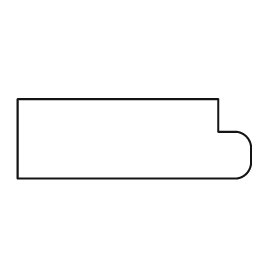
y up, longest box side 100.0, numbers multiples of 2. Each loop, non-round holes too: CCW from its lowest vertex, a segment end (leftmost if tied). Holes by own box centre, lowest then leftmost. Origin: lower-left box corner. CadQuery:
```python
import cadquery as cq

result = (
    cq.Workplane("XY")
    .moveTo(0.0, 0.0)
    .lineTo(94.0, 0.0)
    .threePointArc((98.0, 2.0), (100.0, 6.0))
    .lineTo(100.0, 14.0)
    .threePointArc((98.0, 18.0), (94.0, 20.0))
    .lineTo(86.0, 20.0)
    .lineTo(86.0, 34.0)
    .lineTo(0.0, 34.0)
    .close()
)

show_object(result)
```